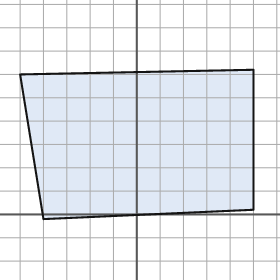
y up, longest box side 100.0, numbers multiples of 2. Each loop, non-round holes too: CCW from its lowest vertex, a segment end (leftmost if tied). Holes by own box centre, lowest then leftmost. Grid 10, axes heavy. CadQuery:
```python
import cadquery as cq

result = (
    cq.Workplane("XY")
    .moveTo(-40.0, -2.0)
    .lineTo(50.0, 2.0)
    .lineTo(50.0, 62.0)
    .lineTo(-50.0, 60.0)
    .close()
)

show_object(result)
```